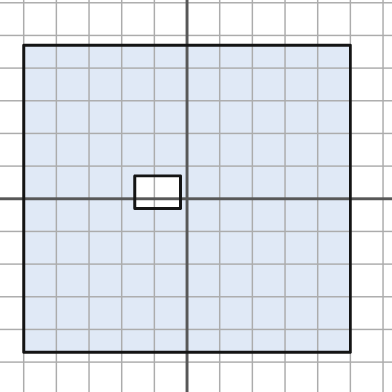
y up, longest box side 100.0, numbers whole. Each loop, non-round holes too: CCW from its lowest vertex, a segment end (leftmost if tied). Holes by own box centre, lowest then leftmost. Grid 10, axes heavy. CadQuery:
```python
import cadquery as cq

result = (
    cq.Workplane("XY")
    .moveTo(-50.0, -47.0)
    .lineTo(50.0, -47.0)
    .lineTo(50.0, 47.0)
    .lineTo(-50.0, 47.0)
    .close()
    .moveTo(-16.0, -3.0)
    .lineTo(-2.0, -3.0)
    .lineTo(-2.0, 7.0)
    .lineTo(-16.0, 7.0)
    .close()
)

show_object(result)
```